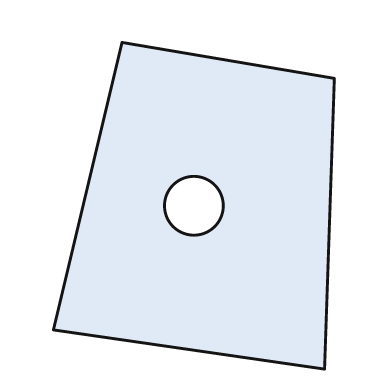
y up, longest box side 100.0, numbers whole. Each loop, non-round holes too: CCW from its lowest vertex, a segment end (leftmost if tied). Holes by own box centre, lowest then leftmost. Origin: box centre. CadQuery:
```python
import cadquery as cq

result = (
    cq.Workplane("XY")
    .moveTo(40.0, -50.0)
    .lineTo(43.0, 39.0)
    .lineTo(-22.0, 50.0)
    .lineTo(-43.0, -38.0)
    .close()
    .moveTo(0.0, 0.0)
    .circle(9.0)
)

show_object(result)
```